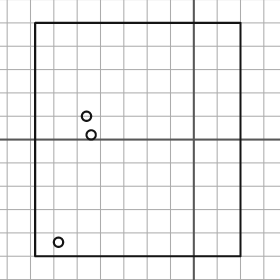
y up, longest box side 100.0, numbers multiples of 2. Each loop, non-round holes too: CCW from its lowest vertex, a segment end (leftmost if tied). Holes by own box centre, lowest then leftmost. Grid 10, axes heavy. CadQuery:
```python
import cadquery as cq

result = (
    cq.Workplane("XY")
    .moveTo(-68.0, -50.0)
    .lineTo(20.0, -50.0)
    .lineTo(20.0, 50.0)
    .lineTo(-68.0, 50.0)
    .close()
    .moveTo(-58.0, -44.0)
    .circle(2.0)
    .moveTo(-44.0, 2.0)
    .circle(2.0)
    .moveTo(-46.0, 10.0)
    .circle(2.0)
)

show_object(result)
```